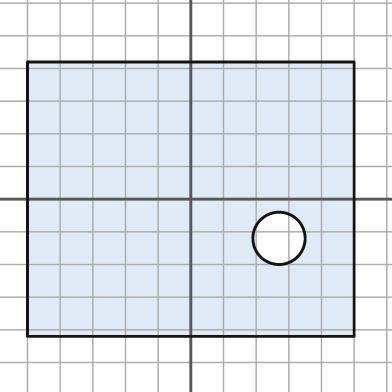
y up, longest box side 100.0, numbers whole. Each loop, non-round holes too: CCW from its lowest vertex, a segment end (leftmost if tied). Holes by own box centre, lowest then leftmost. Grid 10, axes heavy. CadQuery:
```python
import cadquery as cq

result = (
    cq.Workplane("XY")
    .moveTo(-50.0, -42.0)
    .lineTo(50.0, -42.0)
    .lineTo(50.0, 42.0)
    .lineTo(-50.0, 42.0)
    .close()
    .moveTo(27.0, -12.0)
    .circle(8.0)
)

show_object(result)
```